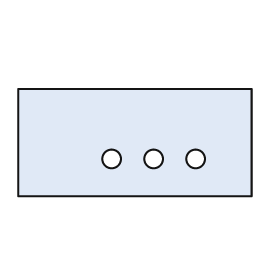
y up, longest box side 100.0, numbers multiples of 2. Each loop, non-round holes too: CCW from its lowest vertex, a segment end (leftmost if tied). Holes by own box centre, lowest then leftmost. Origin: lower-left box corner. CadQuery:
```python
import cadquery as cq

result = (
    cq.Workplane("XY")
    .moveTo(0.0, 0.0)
    .lineTo(100.0, 0.0)
    .lineTo(100.0, 46.0)
    .lineTo(0.0, 46.0)
    .close()
    .moveTo(40.0, 16.0)
    .circle(4.0)
    .moveTo(58.0, 16.0)
    .circle(4.0)
    .moveTo(76.0, 16.0)
    .circle(4.0)
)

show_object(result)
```